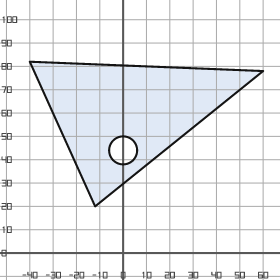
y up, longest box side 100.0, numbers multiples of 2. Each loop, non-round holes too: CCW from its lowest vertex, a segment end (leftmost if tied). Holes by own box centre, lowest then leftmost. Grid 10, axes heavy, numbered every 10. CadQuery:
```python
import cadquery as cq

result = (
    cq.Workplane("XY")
    .moveTo(-12.0, 20.0)
    .lineTo(60.0, 78.0)
    .lineTo(-40.0, 82.0)
    .close()
    .moveTo(0.0, 44.0)
    .circle(6.0)
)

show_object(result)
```